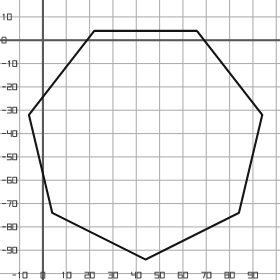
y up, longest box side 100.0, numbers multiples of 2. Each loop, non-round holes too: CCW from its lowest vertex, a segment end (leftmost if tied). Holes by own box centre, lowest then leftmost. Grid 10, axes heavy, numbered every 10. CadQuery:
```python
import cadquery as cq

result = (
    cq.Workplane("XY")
    .moveTo(44.0, -94.0)
    .lineTo(84.0, -74.0)
    .lineTo(94.0, -32.0)
    .lineTo(66.0, 4.0)
    .lineTo(22.0, 4.0)
    .lineTo(-6.0, -32.0)
    .lineTo(4.0, -74.0)
    .close()
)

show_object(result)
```